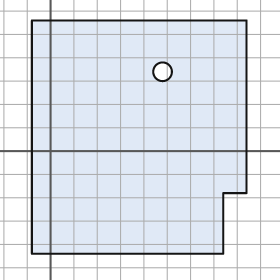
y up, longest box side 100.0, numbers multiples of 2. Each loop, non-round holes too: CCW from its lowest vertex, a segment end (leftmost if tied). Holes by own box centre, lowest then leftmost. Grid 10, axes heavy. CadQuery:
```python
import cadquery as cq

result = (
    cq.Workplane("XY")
    .moveTo(-8.0, -44.0)
    .lineTo(74.0, -44.0)
    .lineTo(74.0, -18.0)
    .lineTo(84.0, -18.0)
    .lineTo(84.0, 56.0)
    .lineTo(-8.0, 56.0)
    .close()
    .moveTo(48.0, 34.0)
    .circle(4.0)
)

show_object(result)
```